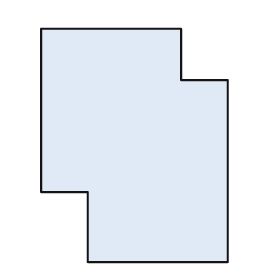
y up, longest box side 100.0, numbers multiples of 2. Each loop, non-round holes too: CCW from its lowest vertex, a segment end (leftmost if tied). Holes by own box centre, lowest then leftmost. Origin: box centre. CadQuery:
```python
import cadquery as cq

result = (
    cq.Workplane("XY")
    .moveTo(-20.0, -50.0)
    .lineTo(40.0, -50.0)
    .lineTo(40.0, 28.0)
    .lineTo(20.0, 28.0)
    .lineTo(20.0, 50.0)
    .lineTo(-40.0, 50.0)
    .lineTo(-40.0, -20.0)
    .lineTo(-20.0, -20.0)
    .close()
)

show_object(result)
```